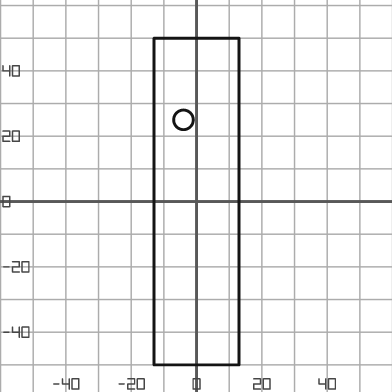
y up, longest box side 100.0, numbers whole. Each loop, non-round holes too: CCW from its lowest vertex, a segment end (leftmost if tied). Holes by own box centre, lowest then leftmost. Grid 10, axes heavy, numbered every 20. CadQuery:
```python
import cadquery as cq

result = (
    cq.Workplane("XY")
    .moveTo(-13.0, -50.0)
    .lineTo(13.0, -50.0)
    .lineTo(13.0, 50.0)
    .lineTo(-13.0, 50.0)
    .close()
    .moveTo(-4.0, 25.0)
    .circle(3.0)
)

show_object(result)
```